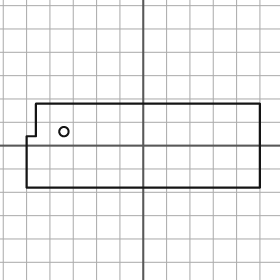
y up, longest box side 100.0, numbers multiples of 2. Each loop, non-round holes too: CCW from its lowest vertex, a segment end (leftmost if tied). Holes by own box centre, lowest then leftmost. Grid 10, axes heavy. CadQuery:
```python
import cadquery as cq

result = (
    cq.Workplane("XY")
    .moveTo(-50.0, -18.0)
    .lineTo(50.0, -18.0)
    .lineTo(50.0, 18.0)
    .lineTo(-46.0, 18.0)
    .lineTo(-46.0, 4.0)
    .lineTo(-50.0, 4.0)
    .close()
    .moveTo(-34.0, 6.0)
    .circle(2.0)
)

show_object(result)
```